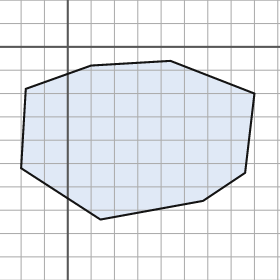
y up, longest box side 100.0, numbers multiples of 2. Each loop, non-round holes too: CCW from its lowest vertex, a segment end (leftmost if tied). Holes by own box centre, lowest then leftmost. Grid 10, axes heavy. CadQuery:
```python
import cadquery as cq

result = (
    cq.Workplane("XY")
    .moveTo(14.0, -74.0)
    .lineTo(58.0, -66.0)
    .lineTo(76.0, -54.0)
    .lineTo(80.0, -20.0)
    .lineTo(44.0, -6.0)
    .lineTo(10.0, -8.0)
    .lineTo(-18.0, -18.0)
    .lineTo(-20.0, -52.0)
    .close()
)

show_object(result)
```